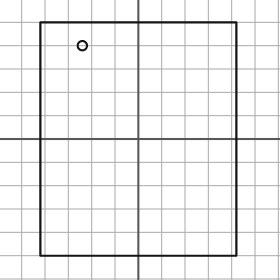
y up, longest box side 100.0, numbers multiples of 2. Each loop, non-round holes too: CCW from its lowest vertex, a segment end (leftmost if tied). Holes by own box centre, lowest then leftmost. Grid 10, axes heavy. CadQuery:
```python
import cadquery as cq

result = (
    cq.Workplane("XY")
    .moveTo(-42.0, -50.0)
    .lineTo(42.0, -50.0)
    .lineTo(42.0, 50.0)
    .lineTo(-42.0, 50.0)
    .close()
    .moveTo(-24.0, 40.0)
    .circle(2.0)
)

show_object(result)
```